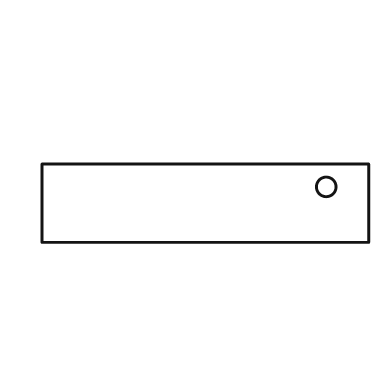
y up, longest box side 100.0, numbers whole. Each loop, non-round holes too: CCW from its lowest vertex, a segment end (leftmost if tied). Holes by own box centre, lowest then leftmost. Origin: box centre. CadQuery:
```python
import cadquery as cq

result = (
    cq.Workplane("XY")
    .moveTo(-50.0, -12.0)
    .lineTo(50.0, -12.0)
    .lineTo(50.0, 12.0)
    .lineTo(-50.0, 12.0)
    .close()
    .moveTo(37.0, 5.0)
    .circle(3.0)
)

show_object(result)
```